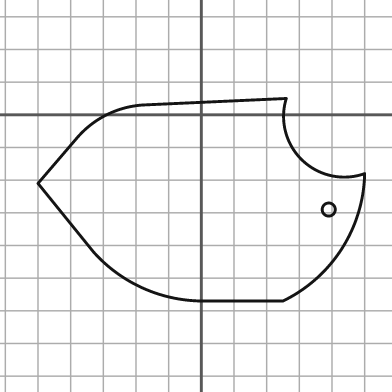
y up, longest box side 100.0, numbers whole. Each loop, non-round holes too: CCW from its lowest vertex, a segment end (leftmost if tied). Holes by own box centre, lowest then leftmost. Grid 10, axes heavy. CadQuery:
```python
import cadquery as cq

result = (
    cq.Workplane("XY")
    .moveTo(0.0, -57.0)
    .lineTo(25.0, -57.0)
    .threePointArc((43.0, -41.0), (50.0, -18.0))
    .threePointArc((31.0, -14.0), (26.0, 5.0))
    .lineTo(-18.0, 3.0)
    .threePointArc((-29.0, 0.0), (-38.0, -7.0))
    .lineTo(-50.0, -21.0)
    .lineTo(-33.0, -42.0)
    .threePointArc((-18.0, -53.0), (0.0, -57.0))
    .close()
    .moveTo(39.0, -29.0)
    .circle(2.0)
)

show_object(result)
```